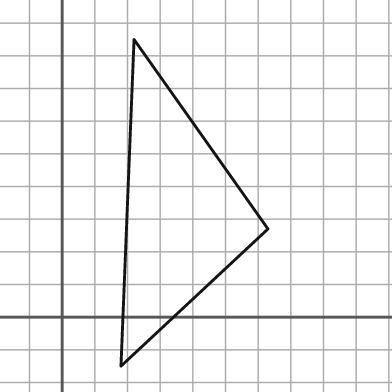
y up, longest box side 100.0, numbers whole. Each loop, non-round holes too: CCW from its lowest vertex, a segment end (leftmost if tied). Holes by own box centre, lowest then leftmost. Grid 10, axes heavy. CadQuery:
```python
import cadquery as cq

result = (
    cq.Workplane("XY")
    .moveTo(18.0, -15.0)
    .lineTo(63.0, 27.0)
    .lineTo(22.0, 85.0)
    .close()
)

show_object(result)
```